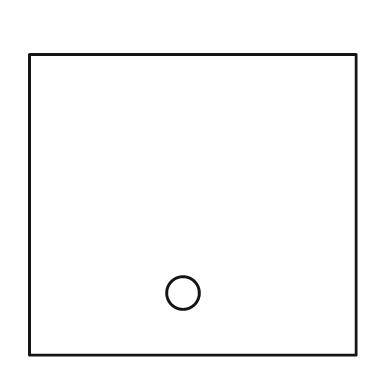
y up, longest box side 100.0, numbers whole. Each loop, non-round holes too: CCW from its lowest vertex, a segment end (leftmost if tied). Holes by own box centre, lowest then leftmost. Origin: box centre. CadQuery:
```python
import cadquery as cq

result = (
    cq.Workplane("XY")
    .moveTo(-50.0, -46.0)
    .lineTo(50.0, -46.0)
    .lineTo(50.0, 46.0)
    .lineTo(-50.0, 46.0)
    .close()
    .moveTo(-3.0, -27.0)
    .circle(5.0)
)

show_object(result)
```